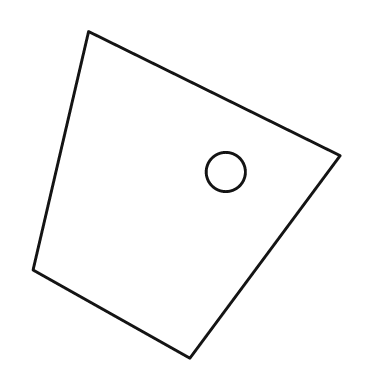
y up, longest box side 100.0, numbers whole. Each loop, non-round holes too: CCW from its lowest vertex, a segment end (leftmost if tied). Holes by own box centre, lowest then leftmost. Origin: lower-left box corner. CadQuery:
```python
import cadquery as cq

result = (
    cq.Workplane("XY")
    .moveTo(48.0, 0.0)
    .lineTo(94.0, 62.0)
    .lineTo(17.0, 100.0)
    .lineTo(0.0, 27.0)
    .close()
    .moveTo(59.0, 57.0)
    .circle(6.0)
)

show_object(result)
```